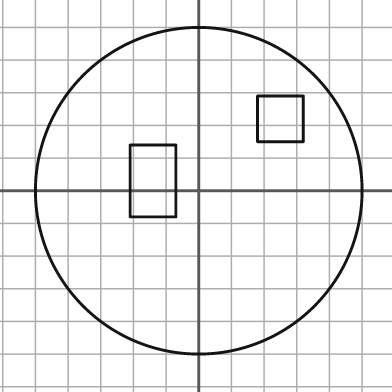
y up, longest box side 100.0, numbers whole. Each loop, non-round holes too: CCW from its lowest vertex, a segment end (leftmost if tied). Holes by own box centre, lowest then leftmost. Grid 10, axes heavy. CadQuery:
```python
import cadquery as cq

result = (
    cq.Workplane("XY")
    .moveTo(0.0, 0.0)
    .circle(50.0)
    .moveTo(-21.0, -8.0)
    .lineTo(-7.0, -8.0)
    .lineTo(-7.0, 14.0)
    .lineTo(-21.0, 14.0)
    .close()
    .moveTo(18.0, 15.0)
    .lineTo(32.0, 15.0)
    .lineTo(32.0, 29.0)
    .lineTo(18.0, 29.0)
    .close()
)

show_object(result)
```